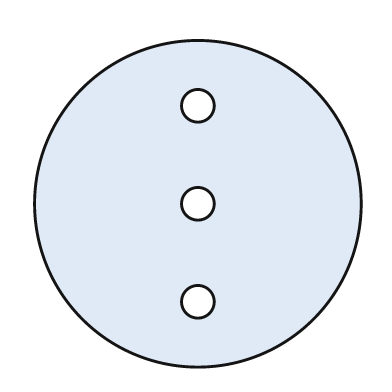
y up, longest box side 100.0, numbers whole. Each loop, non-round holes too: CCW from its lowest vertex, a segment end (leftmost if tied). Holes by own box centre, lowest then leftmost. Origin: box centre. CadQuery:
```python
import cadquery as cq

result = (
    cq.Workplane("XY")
    .moveTo(0.0, 0.0)
    .circle(50.0)
    .moveTo(0.0, -30.0)
    .circle(5.0)
    .moveTo(0.0, 0.0)
    .circle(5.0)
    .moveTo(0.0, 30.0)
    .circle(5.0)
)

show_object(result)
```